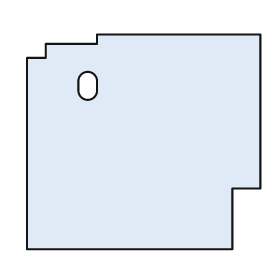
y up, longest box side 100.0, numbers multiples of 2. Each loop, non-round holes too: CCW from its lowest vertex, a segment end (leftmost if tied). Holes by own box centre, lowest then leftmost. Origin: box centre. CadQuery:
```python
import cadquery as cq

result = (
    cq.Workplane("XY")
    .moveTo(-50.0, -46.0)
    .lineTo(38.0, -46.0)
    .lineTo(38.0, -20.0)
    .lineTo(50.0, -20.0)
    .lineTo(50.0, 46.0)
    .lineTo(-20.0, 46.0)
    .lineTo(-20.0, 42.0)
    .lineTo(-42.0, 42.0)
    .lineTo(-42.0, 36.0)
    .lineTo(-50.0, 36.0)
    .close()
    .moveTo(-28.0, 22.0)
    .threePointArc((-24.0, 18.0), (-20.0, 22.0))
    .lineTo(-20.0, 26.0)
    .threePointArc((-24.0, 30.0), (-28.0, 26.0))
    .close()
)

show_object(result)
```